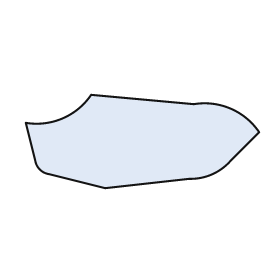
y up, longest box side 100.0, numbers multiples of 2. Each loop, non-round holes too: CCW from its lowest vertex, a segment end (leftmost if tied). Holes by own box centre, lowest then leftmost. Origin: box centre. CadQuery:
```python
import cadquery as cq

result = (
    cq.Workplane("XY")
    .moveTo(-16.0, -20.0)
    .lineTo(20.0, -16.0)
    .threePointArc((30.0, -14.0), (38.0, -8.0))
    .lineTo(50.0, 4.0)
    .threePointArc((38.0, 14.0), (22.0, 16.0))
    .lineTo(-22.0, 20.0)
    .threePointArc((-34.0, 10.0), (-50.0, 8.0))
    .lineTo(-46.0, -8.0)
    .threePointArc((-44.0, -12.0), (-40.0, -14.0))
    .close()
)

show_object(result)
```